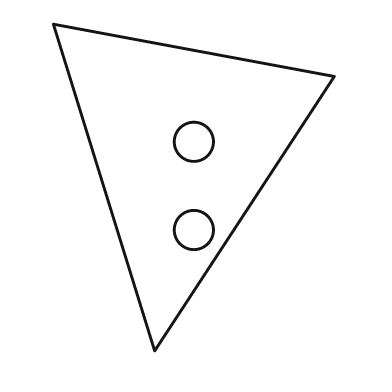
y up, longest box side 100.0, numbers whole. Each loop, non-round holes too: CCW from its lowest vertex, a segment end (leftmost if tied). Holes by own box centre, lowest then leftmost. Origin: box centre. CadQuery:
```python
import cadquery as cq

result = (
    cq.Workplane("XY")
    .moveTo(-12.0, -50.0)
    .lineTo(43.0, 34.0)
    .lineTo(-43.0, 50.0)
    .close()
    .moveTo(0.0, -13.0)
    .circle(6.0)
    .moveTo(0.0, 14.0)
    .circle(6.0)
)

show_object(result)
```